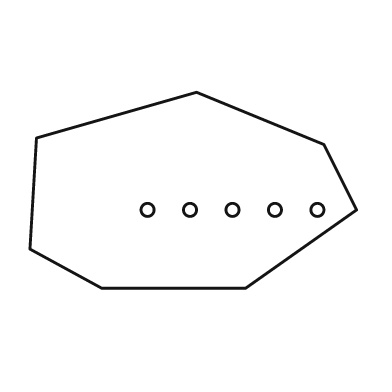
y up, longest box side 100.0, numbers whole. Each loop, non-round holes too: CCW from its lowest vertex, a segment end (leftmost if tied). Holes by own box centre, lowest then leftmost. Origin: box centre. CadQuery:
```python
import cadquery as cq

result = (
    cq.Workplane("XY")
    .moveTo(-28.0, -30.0)
    .lineTo(16.0, -30.0)
    .lineTo(50.0, -6.0)
    .lineTo(40.0, 14.0)
    .lineTo(1.0, 30.0)
    .lineTo(-48.0, 16.0)
    .lineTo(-50.0, -18.0)
    .close()
    .moveTo(-14.0, -6.0)
    .circle(2.0)
    .moveTo(-1.0, -6.0)
    .circle(2.0)
    .moveTo(12.0, -6.0)
    .circle(2.0)
    .moveTo(25.0, -6.0)
    .circle(2.0)
    .moveTo(38.0, -6.0)
    .circle(2.0)
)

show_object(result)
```